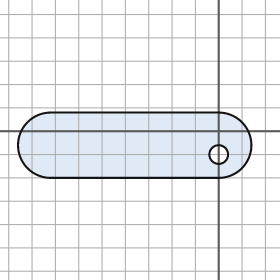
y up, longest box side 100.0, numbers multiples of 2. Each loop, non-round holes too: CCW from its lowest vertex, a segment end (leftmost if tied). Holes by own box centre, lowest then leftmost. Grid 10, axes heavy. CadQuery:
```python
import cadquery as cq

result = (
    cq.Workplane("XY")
    .moveTo(-72.0, -20.0)
    .lineTo(0.0, -20.0)
    .threePointArc((14.0, -6.0), (0.0, 8.0))
    .lineTo(-72.0, 8.0)
    .threePointArc((-86.0, -6.0), (-72.0, -20.0))
    .close()
    .moveTo(0.0, -10.0)
    .circle(4.0)
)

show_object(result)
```